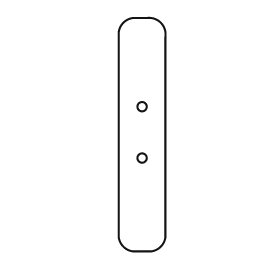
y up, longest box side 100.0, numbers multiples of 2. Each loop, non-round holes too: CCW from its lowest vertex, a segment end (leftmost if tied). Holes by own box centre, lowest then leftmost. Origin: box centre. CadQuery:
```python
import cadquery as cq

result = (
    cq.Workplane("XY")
    .moveTo(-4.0, -50.0)
    .lineTo(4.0, -50.0)
    .threePointArc((8.0, -48.0), (10.0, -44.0))
    .lineTo(10.0, 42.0)
    .threePointArc((8.0, 48.0), (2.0, 50.0))
    .lineTo(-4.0, 50.0)
    .threePointArc((-8.0, 48.0), (-10.0, 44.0))
    .lineTo(-10.0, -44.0)
    .threePointArc((-8.0, -48.0), (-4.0, -50.0))
    .close()
    .moveTo(0.0, -10.0)
    .circle(2.0)
    .moveTo(0.0, 12.0)
    .circle(2.0)
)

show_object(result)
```